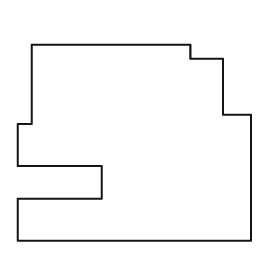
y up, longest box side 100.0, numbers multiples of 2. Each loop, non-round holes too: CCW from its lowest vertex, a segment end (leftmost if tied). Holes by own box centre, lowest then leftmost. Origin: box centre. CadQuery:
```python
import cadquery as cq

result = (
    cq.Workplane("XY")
    .moveTo(-50.0, -42.0)
    .lineTo(50.0, -42.0)
    .lineTo(50.0, 12.0)
    .lineTo(38.0, 12.0)
    .lineTo(38.0, 36.0)
    .lineTo(24.0, 36.0)
    .lineTo(24.0, 42.0)
    .lineTo(-44.0, 42.0)
    .lineTo(-44.0, 8.0)
    .lineTo(-50.0, 8.0)
    .lineTo(-50.0, -10.0)
    .lineTo(-14.0, -10.0)
    .lineTo(-14.0, -24.0)
    .lineTo(-50.0, -24.0)
    .close()
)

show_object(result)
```